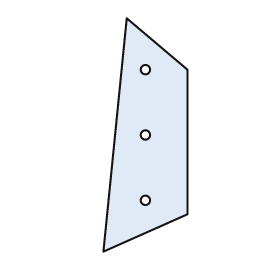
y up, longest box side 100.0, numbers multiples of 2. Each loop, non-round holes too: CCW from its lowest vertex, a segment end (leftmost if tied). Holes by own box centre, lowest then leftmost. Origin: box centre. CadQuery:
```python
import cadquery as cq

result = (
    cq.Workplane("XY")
    .moveTo(-18.0, -50.0)
    .lineTo(18.0, -34.0)
    .lineTo(18.0, 28.0)
    .lineTo(-8.0, 50.0)
    .close()
    .moveTo(0.0, -28.0)
    .circle(2.0)
    .moveTo(0.0, 0.0)
    .circle(2.0)
    .moveTo(0.0, 28.0)
    .circle(2.0)
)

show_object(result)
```